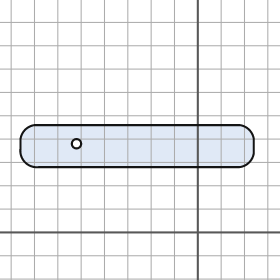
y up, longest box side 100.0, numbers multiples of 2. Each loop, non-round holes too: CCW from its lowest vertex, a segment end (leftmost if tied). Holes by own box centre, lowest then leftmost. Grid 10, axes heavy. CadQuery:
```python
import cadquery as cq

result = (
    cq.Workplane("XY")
    .moveTo(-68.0, 28.0)
    .lineTo(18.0, 28.0)
    .threePointArc((22.0, 30.0), (24.0, 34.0))
    .lineTo(24.0, 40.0)
    .threePointArc((22.0, 44.0), (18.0, 46.0))
    .lineTo(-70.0, 46.0)
    .threePointArc((-74.0, 44.0), (-76.0, 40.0))
    .lineTo(-76.0, 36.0)
    .threePointArc((-74.0, 30.0), (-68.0, 28.0))
    .close()
    .moveTo(-52.0, 38.0)
    .circle(2.0)
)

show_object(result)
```